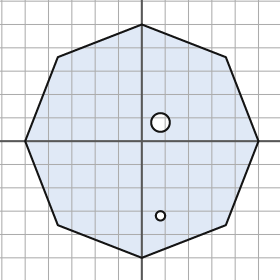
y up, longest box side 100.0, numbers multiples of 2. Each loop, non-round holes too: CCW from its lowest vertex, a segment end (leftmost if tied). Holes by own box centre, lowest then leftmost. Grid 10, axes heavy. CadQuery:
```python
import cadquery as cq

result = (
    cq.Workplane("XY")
    .moveTo(0.0, -50.0)
    .lineTo(36.0, -36.0)
    .lineTo(50.0, 0.0)
    .lineTo(36.0, 36.0)
    .lineTo(0.0, 50.0)
    .lineTo(-36.0, 36.0)
    .lineTo(-50.0, 0.0)
    .lineTo(-36.0, -36.0)
    .close()
    .moveTo(8.0, -32.0)
    .circle(2.0)
    .moveTo(8.0, 8.0)
    .circle(4.0)
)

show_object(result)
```